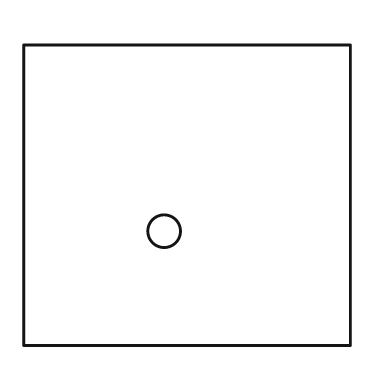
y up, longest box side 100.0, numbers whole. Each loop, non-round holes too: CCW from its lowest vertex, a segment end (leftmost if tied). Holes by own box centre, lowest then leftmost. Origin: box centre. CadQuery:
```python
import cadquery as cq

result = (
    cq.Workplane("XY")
    .moveTo(-50.0, -46.0)
    .lineTo(50.0, -46.0)
    .lineTo(50.0, 46.0)
    .lineTo(-50.0, 46.0)
    .close()
    .moveTo(-7.0, -11.0)
    .circle(5.0)
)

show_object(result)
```